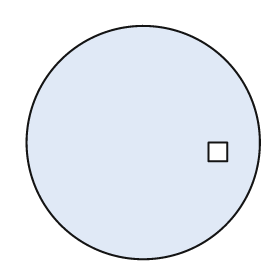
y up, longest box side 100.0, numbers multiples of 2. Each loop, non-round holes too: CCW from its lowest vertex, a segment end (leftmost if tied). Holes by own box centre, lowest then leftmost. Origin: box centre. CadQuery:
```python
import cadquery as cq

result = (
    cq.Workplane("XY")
    .moveTo(0.0, 0.0)
    .circle(50.0)
    .moveTo(28.0, -8.0)
    .lineTo(36.0, -8.0)
    .lineTo(36.0, 0.0)
    .lineTo(28.0, 0.0)
    .close()
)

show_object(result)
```